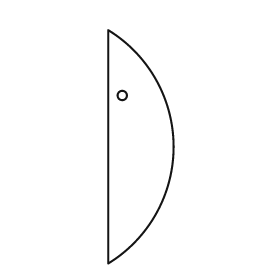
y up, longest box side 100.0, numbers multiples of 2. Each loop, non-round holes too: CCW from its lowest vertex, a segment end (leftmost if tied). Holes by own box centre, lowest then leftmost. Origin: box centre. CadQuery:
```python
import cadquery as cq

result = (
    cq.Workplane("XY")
    .moveTo(-14.0, -50.0)
    .threePointArc((14.0, 0.0), (-14.0, 50.0))
    .close()
    .moveTo(-8.0, 22.0)
    .circle(2.0)
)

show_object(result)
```